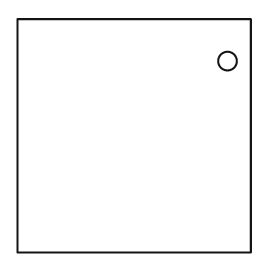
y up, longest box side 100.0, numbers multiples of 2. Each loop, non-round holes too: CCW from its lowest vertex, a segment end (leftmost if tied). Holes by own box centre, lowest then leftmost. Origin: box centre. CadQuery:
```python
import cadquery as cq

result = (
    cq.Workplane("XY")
    .moveTo(-50.0, -50.0)
    .lineTo(50.0, -50.0)
    .lineTo(50.0, 50.0)
    .lineTo(-50.0, 50.0)
    .close()
    .moveTo(40.0, 32.0)
    .circle(4.0)
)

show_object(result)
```